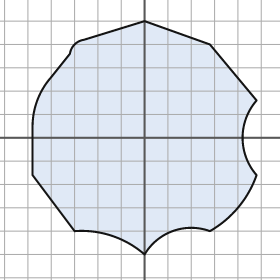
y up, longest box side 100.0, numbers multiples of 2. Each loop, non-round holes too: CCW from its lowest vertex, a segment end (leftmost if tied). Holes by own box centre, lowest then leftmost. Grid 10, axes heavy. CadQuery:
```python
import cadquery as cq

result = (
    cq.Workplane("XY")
    .moveTo(0.0, -50.0)
    .threePointArc((12.0, -40.0), (28.0, -40.0))
    .threePointArc((40.0, -30.0), (48.0, -16.0))
    .threePointArc((42.0, 0.0), (48.0, 16.0))
    .lineTo(28.0, 40.0)
    .lineTo(0.0, 50.0)
    .lineTo(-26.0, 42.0)
    .threePointArc((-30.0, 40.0), (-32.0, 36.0))
    .lineTo(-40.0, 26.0)
    .threePointArc((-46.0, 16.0), (-48.0, 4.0))
    .lineTo(-48.0, -16.0)
    .lineTo(-30.0, -40.0)
    .threePointArc((-14.0, -42.0), (0.0, -50.0))
    .close()
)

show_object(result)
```